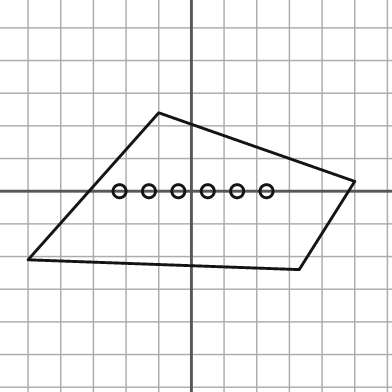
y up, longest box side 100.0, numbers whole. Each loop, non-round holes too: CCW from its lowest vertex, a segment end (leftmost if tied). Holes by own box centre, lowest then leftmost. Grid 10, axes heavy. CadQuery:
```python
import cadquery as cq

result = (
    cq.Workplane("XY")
    .moveTo(33.0, -24.0)
    .lineTo(50.0, 3.0)
    .lineTo(-10.0, 24.0)
    .lineTo(-50.0, -21.0)
    .close()
    .moveTo(-22.0, 0.0)
    .circle(2.0)
    .moveTo(-13.0, 0.0)
    .circle(2.0)
    .moveTo(-4.0, 0.0)
    .circle(2.0)
    .moveTo(5.0, 0.0)
    .circle(2.0)
    .moveTo(14.0, 0.0)
    .circle(2.0)
    .moveTo(23.0, 0.0)
    .circle(2.0)
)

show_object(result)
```